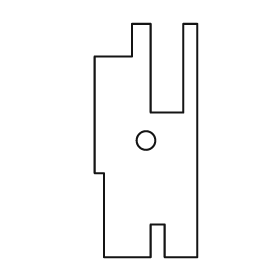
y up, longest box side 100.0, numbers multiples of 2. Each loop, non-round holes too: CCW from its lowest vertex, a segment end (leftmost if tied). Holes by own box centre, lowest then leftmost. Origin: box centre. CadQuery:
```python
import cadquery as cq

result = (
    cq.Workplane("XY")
    .moveTo(-18.0, -50.0)
    .lineTo(2.0, -50.0)
    .lineTo(2.0, -36.0)
    .lineTo(8.0, -36.0)
    .lineTo(8.0, -50.0)
    .lineTo(22.0, -50.0)
    .lineTo(22.0, 50.0)
    .lineTo(16.0, 50.0)
    .lineTo(16.0, 12.0)
    .lineTo(2.0, 12.0)
    .lineTo(2.0, 50.0)
    .lineTo(-6.0, 50.0)
    .lineTo(-6.0, 36.0)
    .lineTo(-22.0, 36.0)
    .lineTo(-22.0, -14.0)
    .lineTo(-18.0, -14.0)
    .close()
    .moveTo(0.0, 0.0)
    .circle(4.0)
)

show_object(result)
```